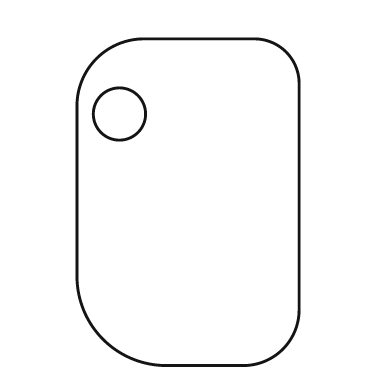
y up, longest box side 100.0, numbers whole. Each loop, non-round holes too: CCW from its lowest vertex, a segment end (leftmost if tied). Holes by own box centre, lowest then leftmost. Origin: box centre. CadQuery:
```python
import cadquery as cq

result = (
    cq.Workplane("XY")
    .moveTo(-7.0, -50.0)
    .lineTo(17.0, -50.0)
    .threePointArc((29.0, -45.0), (34.0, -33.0))
    .lineTo(34.0, 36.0)
    .threePointArc((30.0, 46.0), (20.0, 50.0))
    .lineTo(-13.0, 50.0)
    .threePointArc((-28.0, 44.0), (-34.0, 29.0))
    .lineTo(-34.0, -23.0)
    .threePointArc((-26.0, -42.0), (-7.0, -50.0))
    .close()
    .moveTo(-21.0, 27.0)
    .circle(8.0)
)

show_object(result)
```